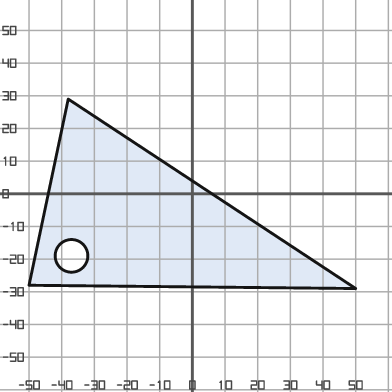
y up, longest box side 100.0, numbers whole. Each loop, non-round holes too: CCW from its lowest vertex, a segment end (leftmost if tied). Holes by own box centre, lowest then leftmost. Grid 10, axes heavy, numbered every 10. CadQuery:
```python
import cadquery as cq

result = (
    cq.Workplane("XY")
    .moveTo(50.0, -29.0)
    .lineTo(-38.0, 29.0)
    .lineTo(-50.0, -28.0)
    .close()
    .moveTo(-37.0, -19.0)
    .circle(5.0)
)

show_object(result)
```